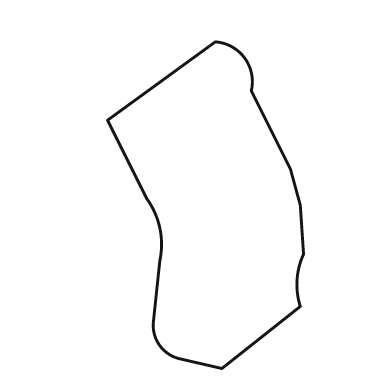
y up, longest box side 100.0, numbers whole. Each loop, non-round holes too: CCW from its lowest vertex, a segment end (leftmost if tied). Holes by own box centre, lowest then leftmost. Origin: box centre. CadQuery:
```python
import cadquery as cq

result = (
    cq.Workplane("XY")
    .moveTo(5.0, -50.0)
    .lineTo(29.0, -31.0)
    .threePointArc((28.0, -23.0), (30.0, -15.0))
    .lineTo(29.0, 0.0)
    .lineTo(26.0, 11.0)
    .lineTo(14.0, 35.0)
    .threePointArc((12.0, 45.0), (3.0, 50.0))
    .lineTo(-30.0, 26.0)
    .lineTo(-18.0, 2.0)
    .threePointArc((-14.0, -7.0), (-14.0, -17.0))
    .lineTo(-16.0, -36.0)
    .threePointArc((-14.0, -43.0), (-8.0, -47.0))
    .close()
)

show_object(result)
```